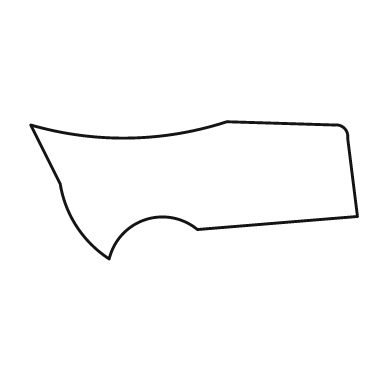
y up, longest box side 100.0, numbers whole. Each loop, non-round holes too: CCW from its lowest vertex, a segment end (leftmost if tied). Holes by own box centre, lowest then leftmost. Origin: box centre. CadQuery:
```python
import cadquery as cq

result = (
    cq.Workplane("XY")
    .moveTo(-26.0, -21.0)
    .threePointArc((-15.0, -9.0), (1.0, -12.0))
    .lineTo(50.0, -8.0)
    .lineTo(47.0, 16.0)
    .threePointArc((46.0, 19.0), (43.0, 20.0))
    .lineTo(10.0, 21.0)
    .threePointArc((-20.0, 16.0), (-50.0, 20.0))
    .lineTo(-41.0, 2.0)
    .threePointArc((-36.0, -11.0), (-26.0, -21.0))
    .close()
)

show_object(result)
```